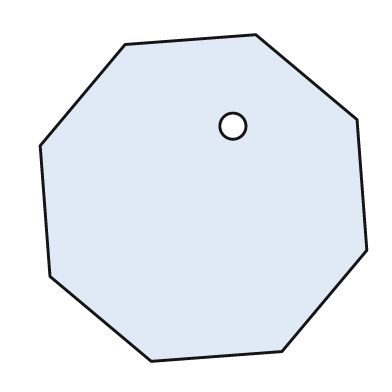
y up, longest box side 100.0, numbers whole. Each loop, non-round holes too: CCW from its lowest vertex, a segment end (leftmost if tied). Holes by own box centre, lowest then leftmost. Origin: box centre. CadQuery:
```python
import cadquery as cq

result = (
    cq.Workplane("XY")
    .moveTo(-16.0, -50.0)
    .lineTo(24.0, -47.0)
    .lineTo(50.0, -16.0)
    .lineTo(47.0, 24.0)
    .lineTo(16.0, 50.0)
    .lineTo(-24.0, 47.0)
    .lineTo(-50.0, 16.0)
    .lineTo(-47.0, -24.0)
    .close()
    .moveTo(9.0, 22.0)
    .circle(4.0)
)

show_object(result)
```